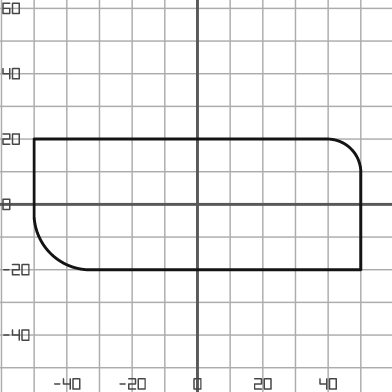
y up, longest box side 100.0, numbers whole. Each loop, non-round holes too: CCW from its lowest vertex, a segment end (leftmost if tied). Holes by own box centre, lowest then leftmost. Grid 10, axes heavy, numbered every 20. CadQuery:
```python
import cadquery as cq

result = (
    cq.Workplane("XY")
    .moveTo(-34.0, -20.0)
    .lineTo(50.0, -20.0)
    .lineTo(50.0, 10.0)
    .threePointArc((47.0, 17.0), (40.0, 20.0))
    .lineTo(-50.0, 20.0)
    .lineTo(-50.0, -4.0)
    .threePointArc((-45.0, -15.0), (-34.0, -20.0))
    .close()
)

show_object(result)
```